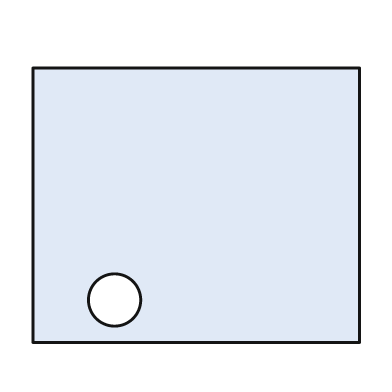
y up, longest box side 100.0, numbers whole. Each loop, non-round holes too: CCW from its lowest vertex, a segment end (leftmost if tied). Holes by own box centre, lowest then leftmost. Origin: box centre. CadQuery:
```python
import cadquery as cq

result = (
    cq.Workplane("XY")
    .moveTo(-50.0, -42.0)
    .lineTo(50.0, -42.0)
    .lineTo(50.0, 42.0)
    .lineTo(-50.0, 42.0)
    .close()
    .moveTo(-25.0, -29.0)
    .circle(8.0)
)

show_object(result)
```